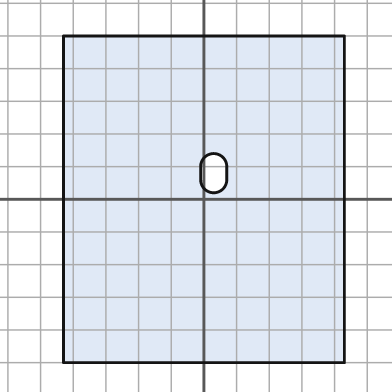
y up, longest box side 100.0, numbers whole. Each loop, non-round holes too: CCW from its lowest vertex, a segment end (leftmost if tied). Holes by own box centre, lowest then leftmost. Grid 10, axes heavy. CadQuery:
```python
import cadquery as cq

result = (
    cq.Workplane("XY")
    .moveTo(-43.0, -50.0)
    .lineTo(43.0, -50.0)
    .lineTo(43.0, 50.0)
    .lineTo(-43.0, 50.0)
    .close()
    .moveTo(-1.0, 6.0)
    .threePointArc((3.0, 2.0), (7.0, 6.0))
    .lineTo(7.0, 10.0)
    .threePointArc((3.0, 14.0), (-1.0, 10.0))
    .close()
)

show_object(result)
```